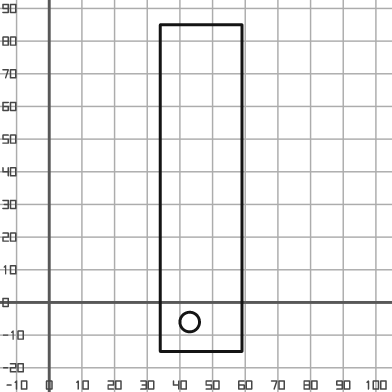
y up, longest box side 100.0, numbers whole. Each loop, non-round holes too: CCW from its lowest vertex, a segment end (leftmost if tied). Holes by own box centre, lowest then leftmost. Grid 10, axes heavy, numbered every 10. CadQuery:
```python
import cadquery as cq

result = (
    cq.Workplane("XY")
    .moveTo(34.0, -15.0)
    .lineTo(59.0, -15.0)
    .lineTo(59.0, 85.0)
    .lineTo(34.0, 85.0)
    .close()
    .moveTo(43.0, -6.0)
    .circle(3.0)
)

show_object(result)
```